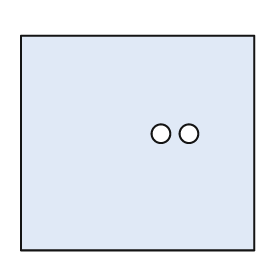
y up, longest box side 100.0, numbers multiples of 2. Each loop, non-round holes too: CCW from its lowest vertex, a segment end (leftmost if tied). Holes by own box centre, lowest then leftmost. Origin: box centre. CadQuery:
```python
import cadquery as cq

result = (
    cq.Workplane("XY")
    .moveTo(-50.0, -46.0)
    .lineTo(50.0, -46.0)
    .lineTo(50.0, 46.0)
    .lineTo(-50.0, 46.0)
    .close()
    .moveTo(10.0, 4.0)
    .circle(4.0)
    .moveTo(22.0, 4.0)
    .circle(4.0)
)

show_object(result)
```